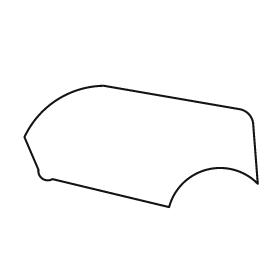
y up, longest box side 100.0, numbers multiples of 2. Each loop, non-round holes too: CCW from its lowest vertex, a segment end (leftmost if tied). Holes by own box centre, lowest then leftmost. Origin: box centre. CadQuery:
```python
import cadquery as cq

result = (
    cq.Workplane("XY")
    .moveTo(12.0, -26.0)
    .threePointArc((28.0, -10.0), (50.0, -16.0))
    .lineTo(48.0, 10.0)
    .threePointArc((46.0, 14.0), (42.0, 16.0))
    .lineTo(-16.0, 26.0)
    .threePointArc((-36.0, 20.0), (-50.0, 4.0))
    .lineTo(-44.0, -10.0)
    .threePointArc((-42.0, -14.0), (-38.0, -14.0))
    .close()
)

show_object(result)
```